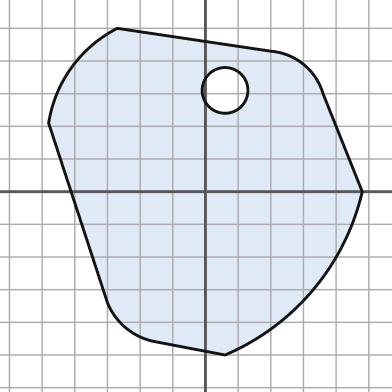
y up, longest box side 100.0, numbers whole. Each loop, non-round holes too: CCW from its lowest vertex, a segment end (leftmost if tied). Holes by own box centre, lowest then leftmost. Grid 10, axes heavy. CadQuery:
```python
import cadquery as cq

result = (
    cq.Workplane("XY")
    .moveTo(6.0, -50.0)
    .threePointArc((33.0, -30.0), (48.0, 0.0))
    .lineTo(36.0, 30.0)
    .threePointArc((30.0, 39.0), (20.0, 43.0))
    .lineTo(-27.0, 50.0)
    .threePointArc((-41.0, 38.0), (-48.0, 21.0))
    .lineTo(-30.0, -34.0)
    .threePointArc((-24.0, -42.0), (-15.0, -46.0))
    .close()
    .moveTo(6.0, 31.0)
    .circle(7.0)
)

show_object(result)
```